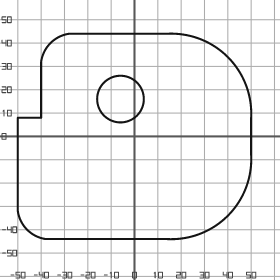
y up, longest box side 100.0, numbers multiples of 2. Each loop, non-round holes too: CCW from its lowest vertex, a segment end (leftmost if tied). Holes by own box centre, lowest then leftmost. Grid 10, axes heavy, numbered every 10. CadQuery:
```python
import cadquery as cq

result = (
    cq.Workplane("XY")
    .moveTo(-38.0, -44.0)
    .lineTo(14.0, -44.0)
    .threePointArc((40.0, -34.0), (50.0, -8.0))
    .lineTo(50.0, 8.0)
    .threePointArc((40.0, 34.0), (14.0, 44.0))
    .lineTo(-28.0, 44.0)
    .threePointArc((-36.0, 40.0), (-40.0, 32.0))
    .lineTo(-40.0, 8.0)
    .lineTo(-50.0, 8.0)
    .lineTo(-50.0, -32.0)
    .threePointArc((-46.0, -40.0), (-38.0, -44.0))
    .close()
    .moveTo(-6.0, 16.0)
    .circle(10.0)
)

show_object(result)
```